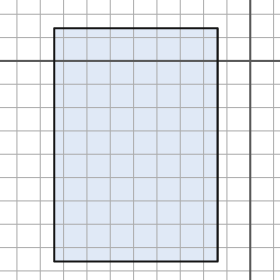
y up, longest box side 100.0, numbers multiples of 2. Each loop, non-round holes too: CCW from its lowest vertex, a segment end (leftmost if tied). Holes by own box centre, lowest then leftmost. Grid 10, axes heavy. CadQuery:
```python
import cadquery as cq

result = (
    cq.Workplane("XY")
    .moveTo(-84.0, -86.0)
    .lineTo(-14.0, -86.0)
    .lineTo(-14.0, 14.0)
    .lineTo(-84.0, 14.0)
    .close()
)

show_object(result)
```